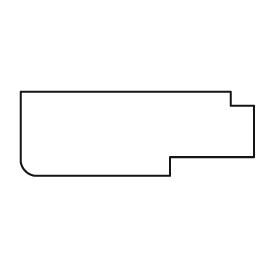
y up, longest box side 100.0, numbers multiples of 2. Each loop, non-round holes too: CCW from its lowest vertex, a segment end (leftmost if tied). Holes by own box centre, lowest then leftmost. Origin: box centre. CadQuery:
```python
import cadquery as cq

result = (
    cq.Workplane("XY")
    .moveTo(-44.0, -18.0)
    .lineTo(14.0, -18.0)
    .lineTo(14.0, -10.0)
    .lineTo(50.0, -10.0)
    .lineTo(50.0, 12.0)
    .lineTo(40.0, 12.0)
    .lineTo(40.0, 18.0)
    .lineTo(-50.0, 18.0)
    .lineTo(-50.0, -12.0)
    .threePointArc((-48.0, -16.0), (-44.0, -18.0))
    .close()
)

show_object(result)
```